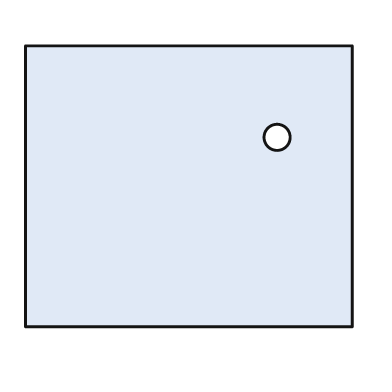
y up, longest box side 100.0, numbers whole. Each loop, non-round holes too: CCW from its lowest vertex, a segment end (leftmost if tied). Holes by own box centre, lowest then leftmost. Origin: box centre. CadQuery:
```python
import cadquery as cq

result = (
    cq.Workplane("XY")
    .moveTo(-50.0, -43.0)
    .lineTo(50.0, -43.0)
    .lineTo(50.0, 43.0)
    .lineTo(-50.0, 43.0)
    .close()
    .moveTo(27.0, 15.0)
    .circle(4.0)
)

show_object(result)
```